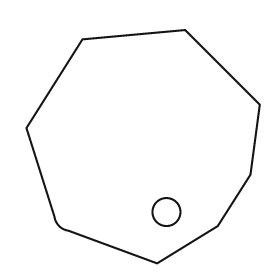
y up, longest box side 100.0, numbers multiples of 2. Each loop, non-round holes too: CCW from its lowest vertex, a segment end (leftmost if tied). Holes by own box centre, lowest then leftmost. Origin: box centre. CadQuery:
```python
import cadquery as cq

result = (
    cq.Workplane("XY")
    .moveTo(6.0, -50.0)
    .lineTo(32.0, -34.0)
    .lineTo(46.0, -12.0)
    .lineTo(50.0, 18.0)
    .lineTo(18.0, 50.0)
    .lineTo(-26.0, 46.0)
    .lineTo(-50.0, 8.0)
    .lineTo(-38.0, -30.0)
    .threePointArc((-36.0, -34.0), (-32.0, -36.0))
    .close()
    .moveTo(10.0, -28.0)
    .circle(6.0)
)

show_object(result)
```